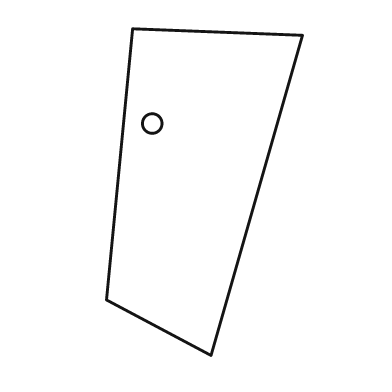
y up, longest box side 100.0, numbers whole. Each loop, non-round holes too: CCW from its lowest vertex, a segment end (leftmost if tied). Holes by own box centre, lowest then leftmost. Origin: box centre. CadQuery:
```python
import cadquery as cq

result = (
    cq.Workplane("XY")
    .moveTo(2.0, -50.0)
    .lineTo(30.0, 48.0)
    .lineTo(-22.0, 50.0)
    .lineTo(-30.0, -33.0)
    .close()
    .moveTo(-16.0, 21.0)
    .circle(3.0)
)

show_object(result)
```